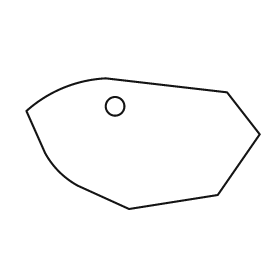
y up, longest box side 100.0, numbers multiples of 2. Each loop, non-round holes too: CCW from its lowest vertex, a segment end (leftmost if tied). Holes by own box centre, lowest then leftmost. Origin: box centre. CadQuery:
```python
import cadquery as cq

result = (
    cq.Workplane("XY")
    .moveTo(-6.0, -28.0)
    .lineTo(32.0, -22.0)
    .lineTo(50.0, 4.0)
    .lineTo(36.0, 22.0)
    .lineTo(-16.0, 28.0)
    .threePointArc((-34.0, 24.0), (-50.0, 14.0))
    .lineTo(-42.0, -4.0)
    .threePointArc((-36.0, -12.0), (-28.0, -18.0))
    .close()
    .moveTo(-12.0, 16.0)
    .circle(4.0)
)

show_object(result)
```